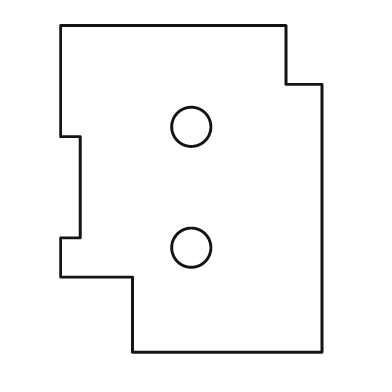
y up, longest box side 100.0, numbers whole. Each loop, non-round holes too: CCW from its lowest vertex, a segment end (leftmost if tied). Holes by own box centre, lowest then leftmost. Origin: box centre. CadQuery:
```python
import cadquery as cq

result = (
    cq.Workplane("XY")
    .moveTo(-18.0, -50.0)
    .lineTo(40.0, -50.0)
    .lineTo(40.0, 32.0)
    .lineTo(29.0, 32.0)
    .lineTo(29.0, 50.0)
    .lineTo(-40.0, 50.0)
    .lineTo(-40.0, 16.0)
    .lineTo(-34.0, 16.0)
    .lineTo(-34.0, -15.0)
    .lineTo(-40.0, -15.0)
    .lineTo(-40.0, -27.0)
    .lineTo(-18.0, -27.0)
    .close()
    .moveTo(0.0, -18.0)
    .circle(6.0)
    .moveTo(0.0, 19.0)
    .circle(6.0)
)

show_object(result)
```